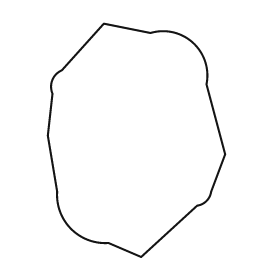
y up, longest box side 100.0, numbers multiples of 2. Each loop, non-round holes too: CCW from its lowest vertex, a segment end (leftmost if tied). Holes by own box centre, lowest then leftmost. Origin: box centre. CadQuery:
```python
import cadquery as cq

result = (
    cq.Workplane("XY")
    .moveTo(2.0, -50.0)
    .lineTo(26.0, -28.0)
    .threePointArc((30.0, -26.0), (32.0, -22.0))
    .lineTo(38.0, -6.0)
    .lineTo(30.0, 24.0)
    .threePointArc((24.0, 42.0), (6.0, 46.0))
    .lineTo(-14.0, 50.0)
    .lineTo(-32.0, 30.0)
    .threePointArc((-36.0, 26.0), (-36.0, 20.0))
    .lineTo(-38.0, 2.0)
    .lineTo(-34.0, -22.0)
    .threePointArc((-28.0, -38.0), (-12.0, -44.0))
    .close()
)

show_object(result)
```